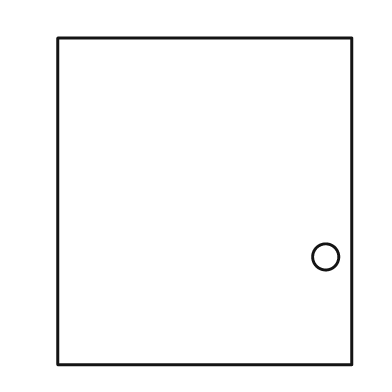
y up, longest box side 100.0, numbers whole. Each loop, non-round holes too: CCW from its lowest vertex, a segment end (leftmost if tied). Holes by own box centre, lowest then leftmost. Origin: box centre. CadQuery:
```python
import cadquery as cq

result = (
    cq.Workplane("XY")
    .moveTo(-45.0, -50.0)
    .lineTo(45.0, -50.0)
    .lineTo(45.0, 50.0)
    .lineTo(-45.0, 50.0)
    .close()
    .moveTo(37.0, -17.0)
    .circle(4.0)
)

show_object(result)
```